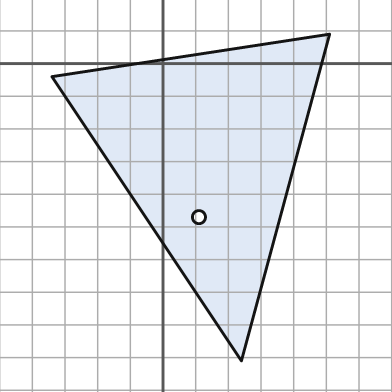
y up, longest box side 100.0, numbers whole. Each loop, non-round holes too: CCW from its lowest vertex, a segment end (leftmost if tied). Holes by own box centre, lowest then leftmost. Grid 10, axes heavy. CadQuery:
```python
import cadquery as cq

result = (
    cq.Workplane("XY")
    .moveTo(24.0, -91.0)
    .lineTo(51.0, 9.0)
    .lineTo(-34.0, -4.0)
    .close()
    .moveTo(11.0, -47.0)
    .circle(2.0)
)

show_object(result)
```